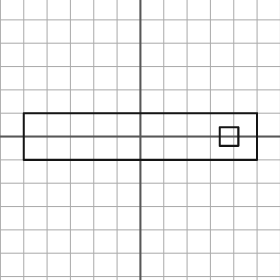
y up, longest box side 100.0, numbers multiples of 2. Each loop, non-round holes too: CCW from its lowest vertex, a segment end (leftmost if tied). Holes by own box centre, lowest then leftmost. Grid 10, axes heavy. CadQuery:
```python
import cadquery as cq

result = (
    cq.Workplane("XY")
    .moveTo(-50.0, -10.0)
    .lineTo(50.0, -10.0)
    .lineTo(50.0, 10.0)
    .lineTo(-50.0, 10.0)
    .close()
    .moveTo(34.0, -4.0)
    .lineTo(42.0, -4.0)
    .lineTo(42.0, 4.0)
    .lineTo(34.0, 4.0)
    .close()
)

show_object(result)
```